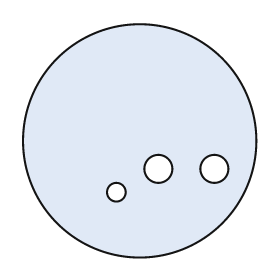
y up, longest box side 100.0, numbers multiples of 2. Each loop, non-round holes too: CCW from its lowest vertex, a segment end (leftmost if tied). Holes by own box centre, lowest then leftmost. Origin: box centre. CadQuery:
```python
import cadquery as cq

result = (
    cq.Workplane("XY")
    .moveTo(0.0, 0.0)
    .circle(50.0)
    .moveTo(-10.0, -22.0)
    .circle(4.0)
    .moveTo(8.0, -12.0)
    .circle(6.0)
    .moveTo(32.0, -12.0)
    .circle(6.0)
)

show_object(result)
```